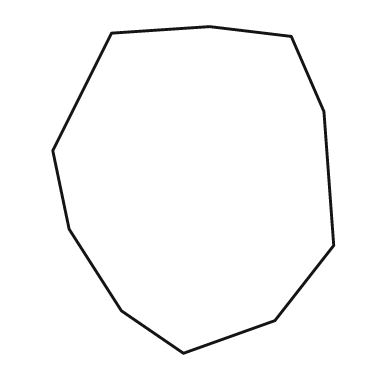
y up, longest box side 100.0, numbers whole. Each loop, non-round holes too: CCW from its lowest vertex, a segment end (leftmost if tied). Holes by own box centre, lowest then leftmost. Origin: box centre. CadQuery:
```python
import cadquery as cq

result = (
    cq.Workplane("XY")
    .moveTo(-3.0, -50.0)
    .lineTo(25.0, -40.0)
    .lineTo(43.0, -17.0)
    .lineTo(40.0, 24.0)
    .lineTo(30.0, 47.0)
    .lineTo(5.0, 50.0)
    .lineTo(-25.0, 48.0)
    .lineTo(-43.0, 12.0)
    .lineTo(-38.0, -12.0)
    .lineTo(-22.0, -37.0)
    .close()
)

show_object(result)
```